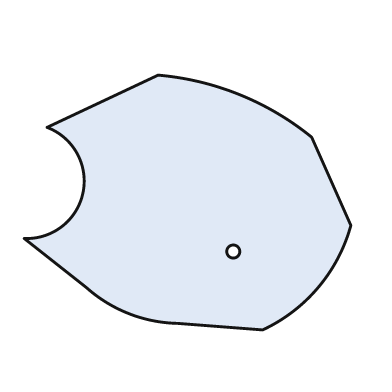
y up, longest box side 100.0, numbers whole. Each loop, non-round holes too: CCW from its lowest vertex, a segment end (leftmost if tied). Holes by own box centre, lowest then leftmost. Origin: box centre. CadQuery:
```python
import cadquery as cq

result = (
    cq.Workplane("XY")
    .moveTo(23.0, -39.0)
    .threePointArc((40.0, -26.0), (50.0, -7.0))
    .lineTo(38.0, 20.0)
    .threePointArc((16.0, 33.0), (-9.0, 39.0))
    .lineTo(-43.0, 23.0)
    .threePointArc((-32.0, 3.0), (-50.0, -11.0))
    .lineTo(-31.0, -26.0)
    .threePointArc((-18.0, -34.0), (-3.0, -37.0))
    .close()
    .moveTo(14.0, -15.0)
    .circle(2.0)
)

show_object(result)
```